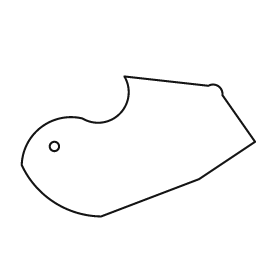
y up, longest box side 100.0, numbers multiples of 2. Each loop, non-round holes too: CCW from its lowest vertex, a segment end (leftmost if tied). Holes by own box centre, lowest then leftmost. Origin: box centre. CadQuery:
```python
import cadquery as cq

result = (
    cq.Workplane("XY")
    .moveTo(-16.0, -30.0)
    .lineTo(26.0, -14.0)
    .lineTo(50.0, 2.0)
    .lineTo(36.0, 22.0)
    .threePointArc((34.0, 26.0), (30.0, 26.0))
    .lineTo(-6.0, 30.0)
    .threePointArc((-8.0, 14.0), (-24.0, 12.0))
    .threePointArc((-42.0, 8.0), (-50.0, -8.0))
    .threePointArc((-36.0, -24.0), (-16.0, -30.0))
    .close()
    .moveTo(-36.0, 0.0)
    .circle(2.0)
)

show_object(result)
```